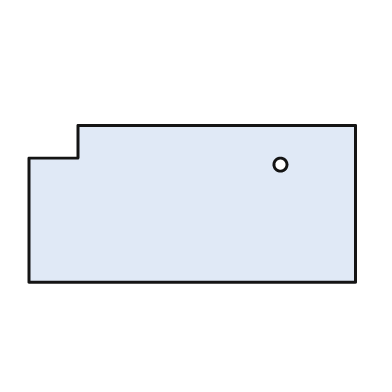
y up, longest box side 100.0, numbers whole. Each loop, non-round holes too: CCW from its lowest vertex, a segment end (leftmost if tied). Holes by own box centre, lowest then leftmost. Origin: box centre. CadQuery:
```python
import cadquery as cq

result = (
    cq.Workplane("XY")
    .moveTo(-50.0, -24.0)
    .lineTo(50.0, -24.0)
    .lineTo(50.0, 24.0)
    .lineTo(-35.0, 24.0)
    .lineTo(-35.0, 14.0)
    .lineTo(-50.0, 14.0)
    .close()
    .moveTo(27.0, 12.0)
    .circle(2.0)
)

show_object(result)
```